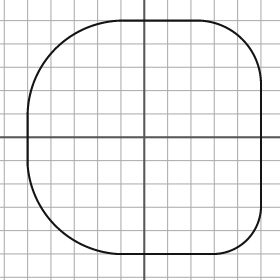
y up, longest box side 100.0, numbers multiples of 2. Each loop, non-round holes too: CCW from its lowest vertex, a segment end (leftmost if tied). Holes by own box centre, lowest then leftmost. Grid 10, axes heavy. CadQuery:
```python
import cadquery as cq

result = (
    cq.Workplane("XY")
    .moveTo(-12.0, -50.0)
    .lineTo(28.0, -50.0)
    .threePointArc((44.0, -44.0), (50.0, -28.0))
    .lineTo(50.0, 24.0)
    .threePointArc((42.0, 42.0), (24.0, 50.0))
    .lineTo(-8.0, 50.0)
    .threePointArc((-38.0, 38.0), (-50.0, 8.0))
    .lineTo(-50.0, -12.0)
    .threePointArc((-38.0, -38.0), (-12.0, -50.0))
    .close()
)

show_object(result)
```